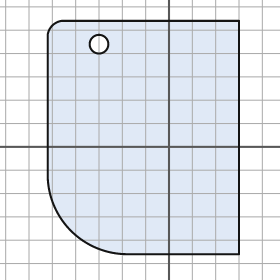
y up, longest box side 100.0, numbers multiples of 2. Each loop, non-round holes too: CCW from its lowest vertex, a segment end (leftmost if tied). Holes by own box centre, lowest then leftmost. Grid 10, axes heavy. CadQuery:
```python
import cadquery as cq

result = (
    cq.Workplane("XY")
    .moveTo(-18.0, -46.0)
    .lineTo(30.0, -46.0)
    .lineTo(30.0, 54.0)
    .lineTo(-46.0, 54.0)
    .threePointArc((-50.0, 52.0), (-52.0, 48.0))
    .lineTo(-52.0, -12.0)
    .threePointArc((-42.0, -36.0), (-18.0, -46.0))
    .close()
    .moveTo(-30.0, 44.0)
    .circle(4.0)
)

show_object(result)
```